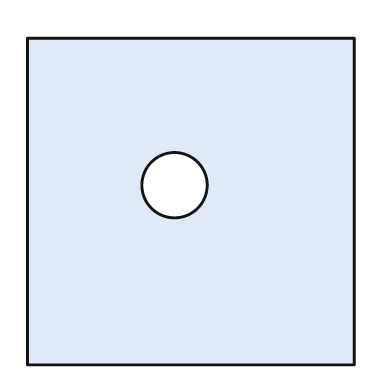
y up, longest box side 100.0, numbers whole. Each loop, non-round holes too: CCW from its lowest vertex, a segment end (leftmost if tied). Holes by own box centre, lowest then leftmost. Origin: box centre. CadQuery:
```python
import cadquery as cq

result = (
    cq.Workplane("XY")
    .moveTo(-50.0, -50.0)
    .lineTo(50.0, -50.0)
    .lineTo(50.0, 50.0)
    .lineTo(-50.0, 50.0)
    .close()
    .moveTo(-5.0, 5.0)
    .circle(10.0)
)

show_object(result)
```